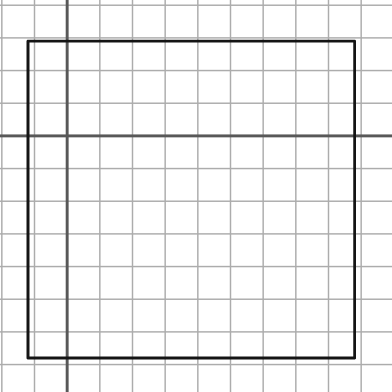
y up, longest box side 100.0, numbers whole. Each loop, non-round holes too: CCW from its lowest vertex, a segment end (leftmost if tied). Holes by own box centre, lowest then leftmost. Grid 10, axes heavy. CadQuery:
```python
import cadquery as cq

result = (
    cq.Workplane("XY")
    .moveTo(-12.0, -68.0)
    .lineTo(88.0, -68.0)
    .lineTo(88.0, 29.0)
    .lineTo(-12.0, 29.0)
    .close()
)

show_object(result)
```